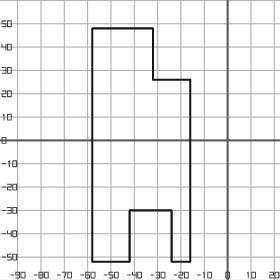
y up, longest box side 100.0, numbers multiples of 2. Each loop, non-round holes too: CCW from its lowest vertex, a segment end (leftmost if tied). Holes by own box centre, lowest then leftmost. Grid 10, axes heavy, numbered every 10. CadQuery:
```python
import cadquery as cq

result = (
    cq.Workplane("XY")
    .moveTo(-58.0, -52.0)
    .lineTo(-42.0, -52.0)
    .lineTo(-42.0, -30.0)
    .lineTo(-24.0, -30.0)
    .lineTo(-24.0, -52.0)
    .lineTo(-16.0, -52.0)
    .lineTo(-16.0, 26.0)
    .lineTo(-32.0, 26.0)
    .lineTo(-32.0, 48.0)
    .lineTo(-58.0, 48.0)
    .close()
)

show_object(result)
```